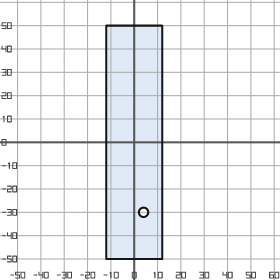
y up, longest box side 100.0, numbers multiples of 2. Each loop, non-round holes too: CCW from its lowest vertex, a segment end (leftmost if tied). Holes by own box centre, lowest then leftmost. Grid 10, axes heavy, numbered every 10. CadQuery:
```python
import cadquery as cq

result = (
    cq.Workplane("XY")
    .moveTo(-12.0, -50.0)
    .lineTo(12.0, -50.0)
    .lineTo(12.0, 50.0)
    .lineTo(-12.0, 50.0)
    .close()
    .moveTo(4.0, -30.0)
    .circle(2.0)
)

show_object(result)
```